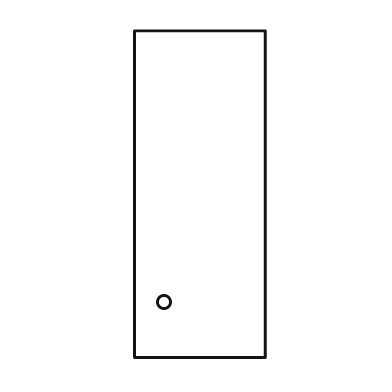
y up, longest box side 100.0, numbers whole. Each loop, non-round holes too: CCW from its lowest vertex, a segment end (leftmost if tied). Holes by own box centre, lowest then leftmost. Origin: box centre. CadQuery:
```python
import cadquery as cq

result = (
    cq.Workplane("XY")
    .moveTo(-20.0, -50.0)
    .lineTo(20.0, -50.0)
    .lineTo(20.0, 50.0)
    .lineTo(-20.0, 50.0)
    .close()
    .moveTo(-11.0, -33.0)
    .circle(2.0)
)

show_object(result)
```